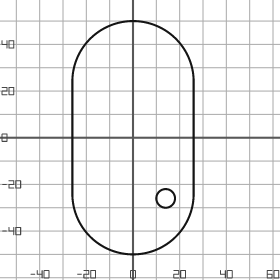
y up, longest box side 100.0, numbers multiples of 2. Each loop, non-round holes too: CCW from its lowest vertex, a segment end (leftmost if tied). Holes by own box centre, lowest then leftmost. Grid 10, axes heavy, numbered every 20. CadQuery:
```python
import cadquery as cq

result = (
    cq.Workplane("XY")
    .moveTo(-26.0, -24.0)
    .threePointArc((0.0, -50.0), (26.0, -24.0))
    .lineTo(26.0, 24.0)
    .threePointArc((0.0, 50.0), (-26.0, 24.0))
    .close()
    .moveTo(14.0, -26.0)
    .circle(4.0)
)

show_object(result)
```